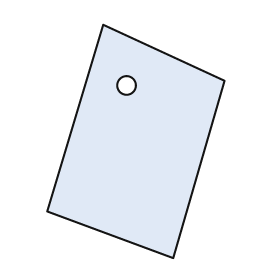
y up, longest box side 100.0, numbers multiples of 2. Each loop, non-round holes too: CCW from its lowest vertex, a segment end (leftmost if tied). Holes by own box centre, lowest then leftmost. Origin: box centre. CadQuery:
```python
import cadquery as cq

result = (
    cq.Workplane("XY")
    .moveTo(16.0, -50.0)
    .lineTo(38.0, 26.0)
    .lineTo(-14.0, 50.0)
    .lineTo(-38.0, -30.0)
    .close()
    .moveTo(-4.0, 24.0)
    .circle(4.0)
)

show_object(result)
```